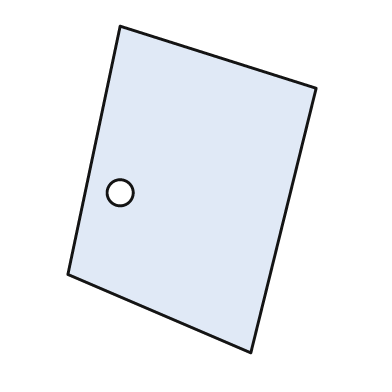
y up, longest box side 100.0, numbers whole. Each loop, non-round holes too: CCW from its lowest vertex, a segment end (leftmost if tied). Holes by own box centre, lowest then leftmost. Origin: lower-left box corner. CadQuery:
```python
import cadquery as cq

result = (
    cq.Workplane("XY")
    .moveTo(56.0, 0.0)
    .lineTo(76.0, 81.0)
    .lineTo(16.0, 100.0)
    .lineTo(0.0, 24.0)
    .close()
    .moveTo(16.0, 49.0)
    .circle(4.0)
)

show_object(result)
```